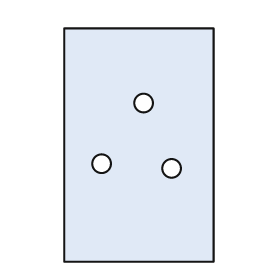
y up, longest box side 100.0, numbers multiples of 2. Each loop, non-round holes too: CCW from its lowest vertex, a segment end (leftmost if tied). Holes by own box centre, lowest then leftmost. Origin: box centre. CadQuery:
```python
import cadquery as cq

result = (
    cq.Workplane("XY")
    .moveTo(-32.0, -50.0)
    .lineTo(32.0, -50.0)
    .lineTo(32.0, 50.0)
    .lineTo(-32.0, 50.0)
    .close()
    .moveTo(14.0, -10.0)
    .circle(4.0)
    .moveTo(-16.0, -8.0)
    .circle(4.0)
    .moveTo(2.0, 18.0)
    .circle(4.0)
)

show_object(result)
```